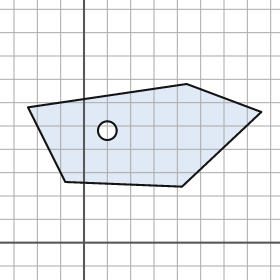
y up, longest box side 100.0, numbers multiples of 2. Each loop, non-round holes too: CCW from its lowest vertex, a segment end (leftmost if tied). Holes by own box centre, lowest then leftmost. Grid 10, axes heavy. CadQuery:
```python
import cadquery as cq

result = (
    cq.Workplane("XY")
    .moveTo(42.0, 24.0)
    .lineTo(76.0, 56.0)
    .lineTo(44.0, 68.0)
    .lineTo(-24.0, 58.0)
    .lineTo(-8.0, 26.0)
    .close()
    .moveTo(10.0, 48.0)
    .circle(4.0)
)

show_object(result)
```